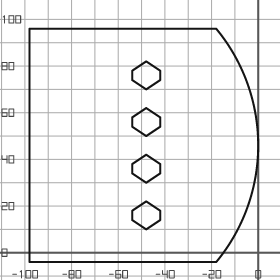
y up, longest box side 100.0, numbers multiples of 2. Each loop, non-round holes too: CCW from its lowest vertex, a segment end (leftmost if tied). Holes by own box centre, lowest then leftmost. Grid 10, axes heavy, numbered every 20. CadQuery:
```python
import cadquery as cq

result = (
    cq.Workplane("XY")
    .moveTo(-98.0, -4.0)
    .lineTo(-18.0, -4.0)
    .threePointArc((0.0, 46.0), (-18.0, 96.0))
    .lineTo(-98.0, 96.0)
    .close()
    .moveTo(-48.0, 10.0)
    .lineTo(-42.0, 14.0)
    .lineTo(-42.0, 18.0)
    .lineTo(-48.0, 22.0)
    .lineTo(-54.0, 18.0)
    .lineTo(-54.0, 14.0)
    .close()
    .moveTo(-48.0, 30.0)
    .lineTo(-42.0, 34.0)
    .lineTo(-42.0, 38.0)
    .lineTo(-48.0, 42.0)
    .lineTo(-54.0, 38.0)
    .lineTo(-54.0, 34.0)
    .close()
    .moveTo(-48.0, 50.0)
    .lineTo(-42.0, 54.0)
    .lineTo(-42.0, 58.0)
    .lineTo(-48.0, 62.0)
    .lineTo(-54.0, 58.0)
    .lineTo(-54.0, 54.0)
    .close()
    .moveTo(-48.0, 70.0)
    .lineTo(-42.0, 74.0)
    .lineTo(-42.0, 78.0)
    .lineTo(-48.0, 82.0)
    .lineTo(-54.0, 78.0)
    .lineTo(-54.0, 74.0)
    .close()
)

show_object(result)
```